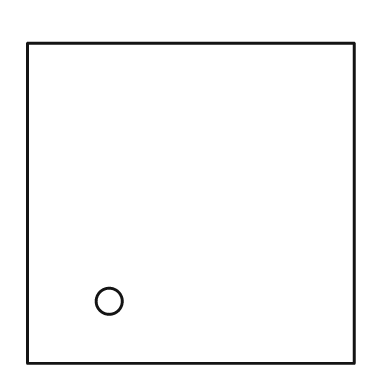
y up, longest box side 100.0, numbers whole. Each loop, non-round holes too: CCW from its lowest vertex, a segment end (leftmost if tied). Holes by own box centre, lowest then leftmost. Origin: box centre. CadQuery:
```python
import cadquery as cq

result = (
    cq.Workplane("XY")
    .moveTo(-50.0, -49.0)
    .lineTo(50.0, -49.0)
    .lineTo(50.0, 49.0)
    .lineTo(-50.0, 49.0)
    .close()
    .moveTo(-25.0, -30.0)
    .circle(4.0)
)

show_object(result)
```